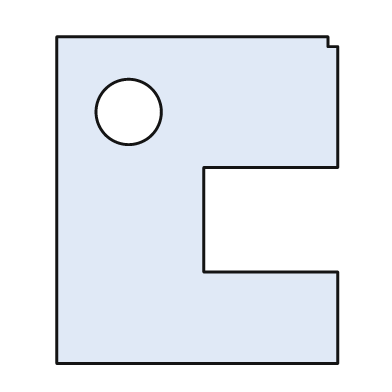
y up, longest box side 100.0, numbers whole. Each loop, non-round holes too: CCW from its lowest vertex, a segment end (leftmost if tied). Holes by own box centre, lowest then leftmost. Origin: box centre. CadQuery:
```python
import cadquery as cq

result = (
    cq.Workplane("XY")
    .moveTo(-43.0, -50.0)
    .lineTo(43.0, -50.0)
    .lineTo(43.0, -22.0)
    .lineTo(2.0, -22.0)
    .lineTo(2.0, 10.0)
    .lineTo(43.0, 10.0)
    .lineTo(43.0, 47.0)
    .lineTo(40.0, 47.0)
    .lineTo(40.0, 50.0)
    .lineTo(-43.0, 50.0)
    .close()
    .moveTo(-21.0, 27.0)
    .circle(10.0)
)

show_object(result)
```